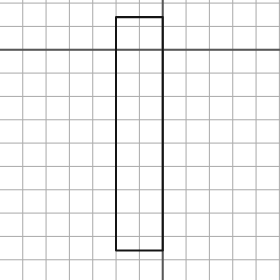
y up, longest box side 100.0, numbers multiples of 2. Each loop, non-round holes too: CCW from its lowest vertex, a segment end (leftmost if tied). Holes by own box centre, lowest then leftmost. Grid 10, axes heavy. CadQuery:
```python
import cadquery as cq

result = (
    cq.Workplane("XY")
    .moveTo(-20.0, -86.0)
    .lineTo(0.0, -86.0)
    .lineTo(0.0, 14.0)
    .lineTo(-20.0, 14.0)
    .close()
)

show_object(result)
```